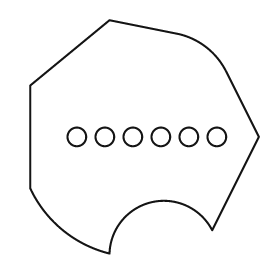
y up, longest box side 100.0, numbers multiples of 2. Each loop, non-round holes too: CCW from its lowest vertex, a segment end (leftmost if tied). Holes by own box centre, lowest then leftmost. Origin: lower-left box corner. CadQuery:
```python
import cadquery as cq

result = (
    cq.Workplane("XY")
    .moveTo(34.0, 0.0)
    .threePointArc((52.0, 22.0), (78.0, 10.0))
    .lineTo(98.0, 50.0)
    .lineTo(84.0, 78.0)
    .threePointArc((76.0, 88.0), (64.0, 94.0))
    .lineTo(34.0, 100.0)
    .lineTo(0.0, 72.0)
    .lineTo(0.0, 28.0)
    .threePointArc((14.0, 10.0), (34.0, 0.0))
    .close()
    .moveTo(20.0, 50.0)
    .circle(4.0)
    .moveTo(32.0, 50.0)
    .circle(4.0)
    .moveTo(44.0, 50.0)
    .circle(4.0)
    .moveTo(56.0, 50.0)
    .circle(4.0)
    .moveTo(68.0, 50.0)
    .circle(4.0)
    .moveTo(80.0, 50.0)
    .circle(4.0)
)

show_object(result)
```